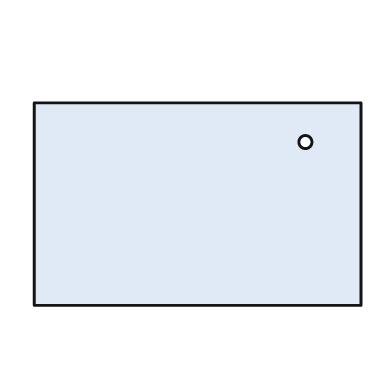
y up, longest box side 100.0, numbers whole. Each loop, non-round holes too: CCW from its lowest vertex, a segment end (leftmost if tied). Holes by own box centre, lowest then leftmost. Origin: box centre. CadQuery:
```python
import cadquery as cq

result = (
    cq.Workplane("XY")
    .moveTo(-50.0, -31.0)
    .lineTo(50.0, -31.0)
    .lineTo(50.0, 31.0)
    .lineTo(-50.0, 31.0)
    .close()
    .moveTo(33.0, 19.0)
    .circle(2.0)
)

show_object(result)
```